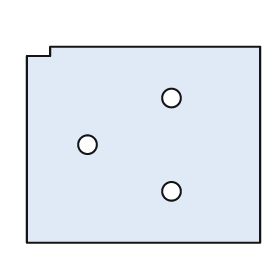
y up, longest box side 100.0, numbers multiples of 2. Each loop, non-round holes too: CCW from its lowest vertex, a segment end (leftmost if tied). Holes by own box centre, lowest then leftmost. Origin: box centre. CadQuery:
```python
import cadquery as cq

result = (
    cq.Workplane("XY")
    .moveTo(-50.0, -42.0)
    .lineTo(50.0, -42.0)
    .lineTo(50.0, 42.0)
    .lineTo(-40.0, 42.0)
    .lineTo(-40.0, 38.0)
    .lineTo(-50.0, 38.0)
    .close()
    .moveTo(12.0, -20.0)
    .circle(4.0)
    .moveTo(-24.0, 0.0)
    .circle(4.0)
    .moveTo(12.0, 20.0)
    .circle(4.0)
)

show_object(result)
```